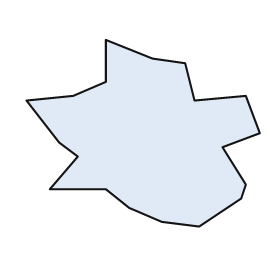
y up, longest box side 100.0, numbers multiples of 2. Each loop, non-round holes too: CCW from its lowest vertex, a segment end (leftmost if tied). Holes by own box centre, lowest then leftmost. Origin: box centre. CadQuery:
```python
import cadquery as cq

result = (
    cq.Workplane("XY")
    .moveTo(24.0, -40.0)
    .lineTo(42.0, -28.0)
    .lineTo(44.0, -22.0)
    .lineTo(34.0, -6.0)
    .lineTo(50.0, 0.0)
    .lineTo(44.0, 16.0)
    .lineTo(22.0, 14.0)
    .lineTo(18.0, 30.0)
    .lineTo(4.0, 32.0)
    .lineTo(-16.0, 40.0)
    .lineTo(-16.0, 22.0)
    .lineTo(-30.0, 16.0)
    .lineTo(-50.0, 14.0)
    .lineTo(-36.0, -4.0)
    .lineTo(-28.0, -10.0)
    .lineTo(-40.0, -24.0)
    .lineTo(-16.0, -24.0)
    .lineTo(-6.0, -32.0)
    .lineTo(8.0, -38.0)
    .close()
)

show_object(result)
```